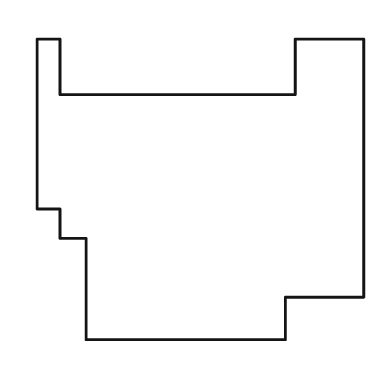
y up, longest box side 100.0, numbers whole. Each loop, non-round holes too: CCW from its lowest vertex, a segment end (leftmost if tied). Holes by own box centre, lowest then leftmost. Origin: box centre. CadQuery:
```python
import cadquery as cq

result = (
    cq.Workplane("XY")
    .moveTo(-35.0, -46.0)
    .lineTo(26.0, -46.0)
    .lineTo(26.0, -33.0)
    .lineTo(50.0, -33.0)
    .lineTo(50.0, 46.0)
    .lineTo(29.0, 46.0)
    .lineTo(29.0, 29.0)
    .lineTo(-43.0, 29.0)
    .lineTo(-43.0, 46.0)
    .lineTo(-50.0, 46.0)
    .lineTo(-50.0, -6.0)
    .lineTo(-43.0, -6.0)
    .lineTo(-43.0, -15.0)
    .lineTo(-35.0, -15.0)
    .close()
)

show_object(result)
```